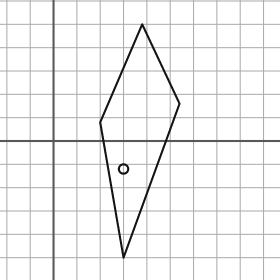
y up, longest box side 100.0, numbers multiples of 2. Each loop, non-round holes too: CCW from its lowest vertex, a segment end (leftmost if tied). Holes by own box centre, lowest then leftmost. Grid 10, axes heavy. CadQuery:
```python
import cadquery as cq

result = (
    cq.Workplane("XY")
    .moveTo(30.0, -50.0)
    .lineTo(54.0, 16.0)
    .lineTo(38.0, 50.0)
    .lineTo(20.0, 8.0)
    .close()
    .moveTo(30.0, -12.0)
    .circle(2.0)
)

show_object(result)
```